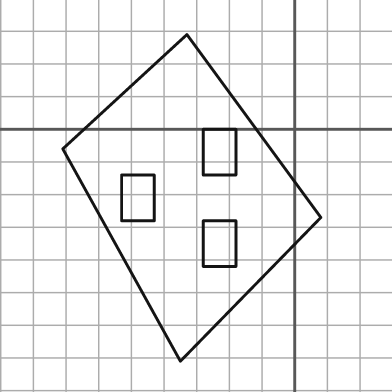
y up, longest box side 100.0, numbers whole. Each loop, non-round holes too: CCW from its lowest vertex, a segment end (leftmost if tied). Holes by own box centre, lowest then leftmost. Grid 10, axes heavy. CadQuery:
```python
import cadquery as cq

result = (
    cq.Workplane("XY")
    .moveTo(-35.0, -71.0)
    .lineTo(8.0, -27.0)
    .lineTo(-33.0, 29.0)
    .lineTo(-71.0, -6.0)
    .close()
    .moveTo(-28.0, -42.0)
    .lineTo(-18.0, -42.0)
    .lineTo(-18.0, -28.0)
    .lineTo(-28.0, -28.0)
    .close()
    .moveTo(-53.0, -28.0)
    .lineTo(-43.0, -28.0)
    .lineTo(-43.0, -14.0)
    .lineTo(-53.0, -14.0)
    .close()
    .moveTo(-28.0, -14.0)
    .lineTo(-18.0, -14.0)
    .lineTo(-18.0, 0.0)
    .lineTo(-28.0, 0.0)
    .close()
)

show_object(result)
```